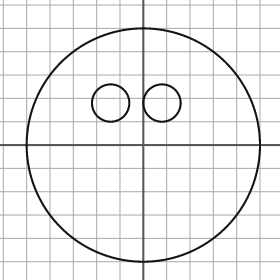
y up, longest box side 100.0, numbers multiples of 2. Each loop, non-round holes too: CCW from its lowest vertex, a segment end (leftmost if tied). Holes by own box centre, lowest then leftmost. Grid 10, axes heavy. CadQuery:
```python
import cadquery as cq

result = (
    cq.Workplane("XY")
    .moveTo(0.0, 0.0)
    .circle(50.0)
    .moveTo(-14.0, 18.0)
    .circle(8.0)
    .moveTo(8.0, 18.0)
    .circle(8.0)
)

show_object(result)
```